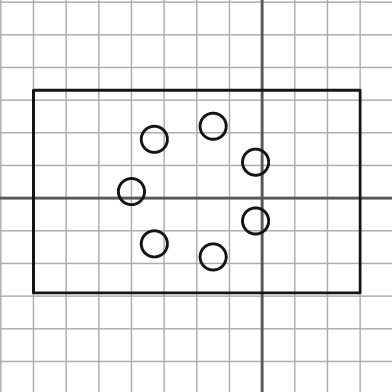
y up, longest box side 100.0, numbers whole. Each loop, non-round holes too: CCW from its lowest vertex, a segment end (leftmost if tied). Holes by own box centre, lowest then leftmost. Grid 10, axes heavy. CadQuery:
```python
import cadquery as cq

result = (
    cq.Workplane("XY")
    .moveTo(-70.0, -29.0)
    .lineTo(30.0, -29.0)
    .lineTo(30.0, 33.0)
    .lineTo(-70.0, 33.0)
    .close()
    .moveTo(-15.0, -18.0)
    .circle(4.0)
    .moveTo(-33.0, -14.0)
    .circle(4.0)
    .moveTo(-2.0, -7.0)
    .circle(4.0)
    .moveTo(-40.0, 2.0)
    .circle(4.0)
    .moveTo(-2.0, 11.0)
    .circle(4.0)
    .moveTo(-33.0, 18.0)
    .circle(4.0)
    .moveTo(-15.0, 22.0)
    .circle(4.0)
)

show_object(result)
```